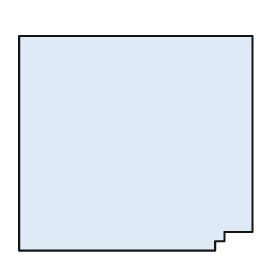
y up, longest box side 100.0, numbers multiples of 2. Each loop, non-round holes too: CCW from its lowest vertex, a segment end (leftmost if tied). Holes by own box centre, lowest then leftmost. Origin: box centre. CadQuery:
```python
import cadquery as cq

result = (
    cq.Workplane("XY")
    .moveTo(-50.0, -46.0)
    .lineTo(34.0, -46.0)
    .lineTo(34.0, -42.0)
    .lineTo(38.0, -42.0)
    .lineTo(38.0, -38.0)
    .lineTo(50.0, -38.0)
    .lineTo(50.0, 46.0)
    .lineTo(-50.0, 46.0)
    .close()
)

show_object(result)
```